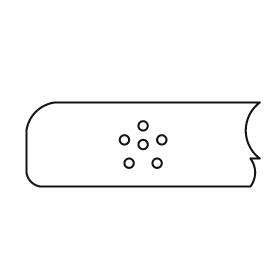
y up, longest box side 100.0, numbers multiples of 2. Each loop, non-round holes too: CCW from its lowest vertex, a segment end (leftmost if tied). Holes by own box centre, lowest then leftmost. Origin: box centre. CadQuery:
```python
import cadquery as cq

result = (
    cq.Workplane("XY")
    .moveTo(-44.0, -18.0)
    .lineTo(46.0, -18.0)
    .threePointArc((48.0, -12.0), (46.0, -6.0))
    .lineTo(50.0, -6.0)
    .threePointArc((44.0, 6.0), (50.0, 18.0))
    .lineTo(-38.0, 18.0)
    .threePointArc((-46.0, 14.0), (-50.0, 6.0))
    .lineTo(-50.0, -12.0)
    .threePointArc((-48.0, -16.0), (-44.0, -18.0))
    .close()
    .moveTo(-6.0, -8.0)
    .circle(2.0)
    .moveTo(6.0, -8.0)
    .circle(2.0)
    .moveTo(0.0, 0.0)
    .circle(2.0)
    .moveTo(-8.0, 2.0)
    .circle(2.0)
    .moveTo(8.0, 2.0)
    .circle(2.0)
    .moveTo(0.0, 8.0)
    .circle(2.0)
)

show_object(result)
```